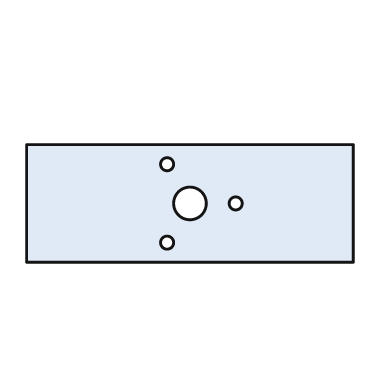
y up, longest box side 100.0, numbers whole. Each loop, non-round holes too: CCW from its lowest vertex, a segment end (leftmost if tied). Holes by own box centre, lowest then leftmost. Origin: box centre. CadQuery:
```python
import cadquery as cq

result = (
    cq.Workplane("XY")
    .moveTo(-50.0, -18.0)
    .lineTo(50.0, -18.0)
    .lineTo(50.0, 18.0)
    .lineTo(-50.0, 18.0)
    .close()
    .moveTo(-7.0, -12.0)
    .circle(2.0)
    .moveTo(0.0, 0.0)
    .circle(5.0)
    .moveTo(14.0, 0.0)
    .circle(2.0)
    .moveTo(-7.0, 12.0)
    .circle(2.0)
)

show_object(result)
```